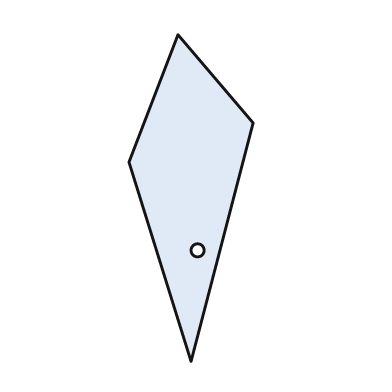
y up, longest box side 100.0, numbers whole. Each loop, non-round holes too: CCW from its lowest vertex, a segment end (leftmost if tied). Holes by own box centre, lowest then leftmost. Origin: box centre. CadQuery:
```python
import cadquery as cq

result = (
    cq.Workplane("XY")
    .moveTo(0.0, -50.0)
    .lineTo(19.0, 23.0)
    .lineTo(-4.0, 50.0)
    .lineTo(-19.0, 11.0)
    .close()
    .moveTo(2.0, -16.0)
    .circle(2.0)
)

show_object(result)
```